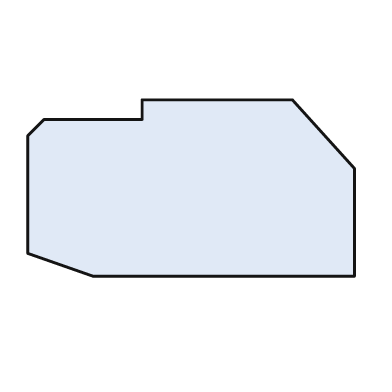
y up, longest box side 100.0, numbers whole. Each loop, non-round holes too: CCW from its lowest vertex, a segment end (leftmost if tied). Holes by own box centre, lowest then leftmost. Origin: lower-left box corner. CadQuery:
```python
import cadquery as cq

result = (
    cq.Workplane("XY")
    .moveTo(20.0, 0.0)
    .lineTo(100.0, 0.0)
    .lineTo(100.0, 33.0)
    .lineTo(81.0, 54.0)
    .lineTo(35.0, 54.0)
    .lineTo(35.0, 48.0)
    .lineTo(5.0, 48.0)
    .lineTo(0.0, 43.0)
    .lineTo(0.0, 7.0)
    .close()
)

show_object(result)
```